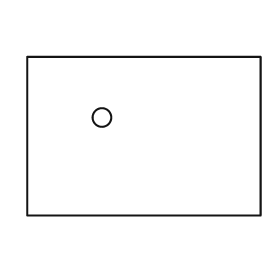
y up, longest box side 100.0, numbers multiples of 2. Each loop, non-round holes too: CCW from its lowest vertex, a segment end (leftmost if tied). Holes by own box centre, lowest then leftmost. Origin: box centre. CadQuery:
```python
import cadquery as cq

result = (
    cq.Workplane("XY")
    .moveTo(-50.0, -34.0)
    .lineTo(50.0, -34.0)
    .lineTo(50.0, 34.0)
    .lineTo(-50.0, 34.0)
    .close()
    .moveTo(-18.0, 8.0)
    .circle(4.0)
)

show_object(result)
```